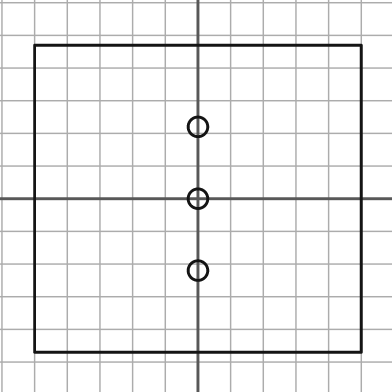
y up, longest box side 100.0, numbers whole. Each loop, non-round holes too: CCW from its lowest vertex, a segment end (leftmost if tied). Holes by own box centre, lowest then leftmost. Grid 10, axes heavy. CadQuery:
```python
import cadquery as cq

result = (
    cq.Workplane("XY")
    .moveTo(-50.0, -47.0)
    .lineTo(50.0, -47.0)
    .lineTo(50.0, 47.0)
    .lineTo(-50.0, 47.0)
    .close()
    .moveTo(0.0, -22.0)
    .circle(3.0)
    .moveTo(0.0, 0.0)
    .circle(3.0)
    .moveTo(0.0, 22.0)
    .circle(3.0)
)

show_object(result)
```